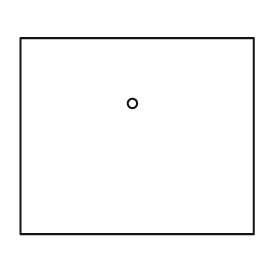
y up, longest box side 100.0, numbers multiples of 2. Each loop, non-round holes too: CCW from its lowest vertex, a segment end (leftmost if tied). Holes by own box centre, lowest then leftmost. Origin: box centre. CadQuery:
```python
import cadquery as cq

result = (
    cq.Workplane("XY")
    .moveTo(-50.0, -42.0)
    .lineTo(50.0, -42.0)
    .lineTo(50.0, 42.0)
    .lineTo(-50.0, 42.0)
    .close()
    .moveTo(-2.0, 14.0)
    .circle(2.0)
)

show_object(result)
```